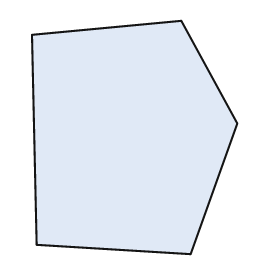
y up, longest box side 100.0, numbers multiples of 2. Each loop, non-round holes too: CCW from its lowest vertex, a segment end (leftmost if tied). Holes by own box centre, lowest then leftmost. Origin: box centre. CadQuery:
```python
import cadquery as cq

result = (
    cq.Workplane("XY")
    .moveTo(24.0, -50.0)
    .lineTo(44.0, 6.0)
    .lineTo(20.0, 50.0)
    .lineTo(-44.0, 44.0)
    .lineTo(-42.0, -46.0)
    .close()
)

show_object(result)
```